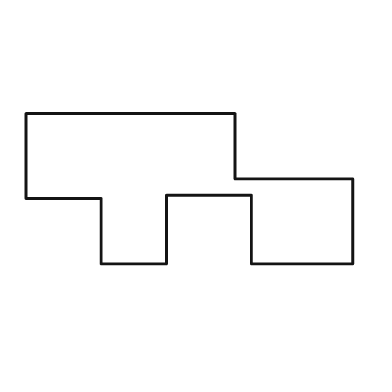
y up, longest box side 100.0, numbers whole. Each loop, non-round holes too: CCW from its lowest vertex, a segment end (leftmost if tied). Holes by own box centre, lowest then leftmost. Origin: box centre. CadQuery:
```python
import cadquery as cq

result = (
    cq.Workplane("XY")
    .moveTo(-27.0, -23.0)
    .lineTo(-7.0, -23.0)
    .lineTo(-7.0, -2.0)
    .lineTo(19.0, -2.0)
    .lineTo(19.0, -23.0)
    .lineTo(50.0, -23.0)
    .lineTo(50.0, 3.0)
    .lineTo(14.0, 3.0)
    .lineTo(14.0, 23.0)
    .lineTo(-50.0, 23.0)
    .lineTo(-50.0, -3.0)
    .lineTo(-27.0, -3.0)
    .close()
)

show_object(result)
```